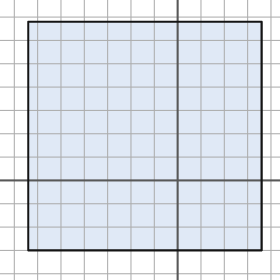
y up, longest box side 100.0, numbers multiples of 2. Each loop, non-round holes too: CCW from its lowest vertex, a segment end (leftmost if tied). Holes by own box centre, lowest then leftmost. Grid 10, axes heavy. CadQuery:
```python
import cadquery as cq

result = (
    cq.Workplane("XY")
    .moveTo(-64.0, -30.0)
    .lineTo(36.0, -30.0)
    .lineTo(36.0, 68.0)
    .lineTo(-64.0, 68.0)
    .close()
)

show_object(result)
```